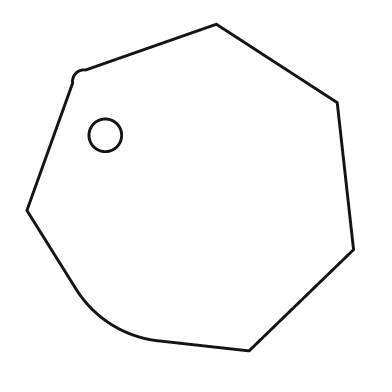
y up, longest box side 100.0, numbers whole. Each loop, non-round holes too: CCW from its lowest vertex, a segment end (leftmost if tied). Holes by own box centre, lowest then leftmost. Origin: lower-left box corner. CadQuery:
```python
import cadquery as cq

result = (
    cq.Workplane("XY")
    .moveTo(68.0, 0.0)
    .lineTo(100.0, 31.0)
    .lineTo(95.0, 76.0)
    .lineTo(58.0, 100.0)
    .lineTo(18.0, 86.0)
    .threePointArc((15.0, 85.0), (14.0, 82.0))
    .lineTo(0.0, 43.0)
    .lineTo(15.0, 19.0)
    .threePointArc((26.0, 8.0), (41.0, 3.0))
    .close()
    .moveTo(24.0, 66.0)
    .circle(5.0)
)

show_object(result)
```